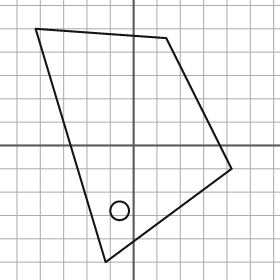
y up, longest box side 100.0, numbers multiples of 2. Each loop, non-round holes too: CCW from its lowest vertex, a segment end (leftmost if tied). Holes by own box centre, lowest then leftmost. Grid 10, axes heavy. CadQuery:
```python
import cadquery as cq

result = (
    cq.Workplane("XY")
    .moveTo(-12.0, -50.0)
    .lineTo(42.0, -10.0)
    .lineTo(14.0, 46.0)
    .lineTo(-42.0, 50.0)
    .close()
    .moveTo(-6.0, -28.0)
    .circle(4.0)
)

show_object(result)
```